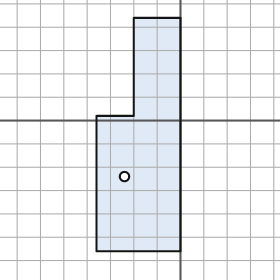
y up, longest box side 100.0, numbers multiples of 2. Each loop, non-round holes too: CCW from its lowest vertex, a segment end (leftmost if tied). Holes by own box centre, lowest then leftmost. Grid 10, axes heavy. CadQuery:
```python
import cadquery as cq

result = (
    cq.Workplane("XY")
    .moveTo(-36.0, -56.0)
    .lineTo(0.0, -56.0)
    .lineTo(0.0, 44.0)
    .lineTo(-20.0, 44.0)
    .lineTo(-20.0, 2.0)
    .lineTo(-36.0, 2.0)
    .close()
    .moveTo(-24.0, -24.0)
    .circle(2.0)
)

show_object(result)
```